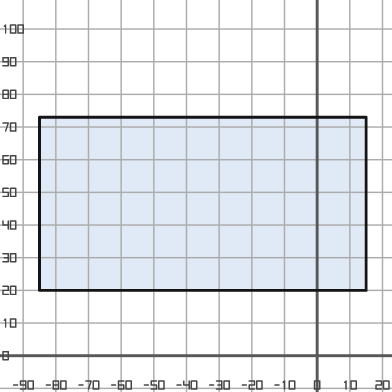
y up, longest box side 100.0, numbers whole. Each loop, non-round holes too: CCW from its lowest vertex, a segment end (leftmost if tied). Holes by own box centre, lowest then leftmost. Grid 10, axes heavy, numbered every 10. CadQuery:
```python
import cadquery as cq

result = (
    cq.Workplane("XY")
    .moveTo(-85.0, 20.0)
    .lineTo(15.0, 20.0)
    .lineTo(15.0, 73.0)
    .lineTo(-85.0, 73.0)
    .close()
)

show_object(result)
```